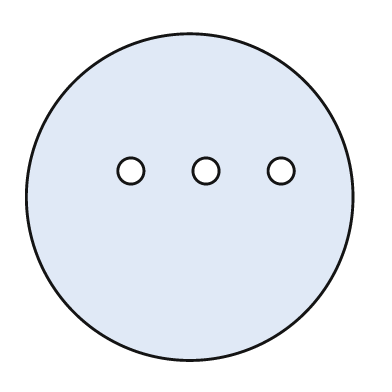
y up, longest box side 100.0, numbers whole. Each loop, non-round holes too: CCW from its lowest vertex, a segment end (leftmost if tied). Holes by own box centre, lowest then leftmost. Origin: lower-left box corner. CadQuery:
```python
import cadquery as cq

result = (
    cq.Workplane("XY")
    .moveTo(50.0, 50.0)
    .circle(50.0)
    .moveTo(32.0, 58.0)
    .circle(4.0)
    .moveTo(55.0, 58.0)
    .circle(4.0)
    .moveTo(78.0, 58.0)
    .circle(4.0)
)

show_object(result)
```